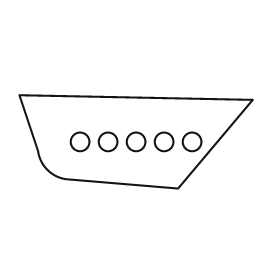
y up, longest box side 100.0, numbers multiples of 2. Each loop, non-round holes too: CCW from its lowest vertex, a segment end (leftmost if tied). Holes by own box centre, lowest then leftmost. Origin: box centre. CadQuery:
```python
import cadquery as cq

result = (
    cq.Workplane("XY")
    .moveTo(18.0, -20.0)
    .lineTo(50.0, 18.0)
    .lineTo(-50.0, 20.0)
    .lineTo(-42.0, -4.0)
    .threePointArc((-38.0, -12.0), (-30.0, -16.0))
    .close()
    .moveTo(-24.0, 0.0)
    .circle(4.0)
    .moveTo(-12.0, 0.0)
    .circle(4.0)
    .moveTo(0.0, 0.0)
    .circle(4.0)
    .moveTo(12.0, 0.0)
    .circle(4.0)
    .moveTo(24.0, 0.0)
    .circle(4.0)
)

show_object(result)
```